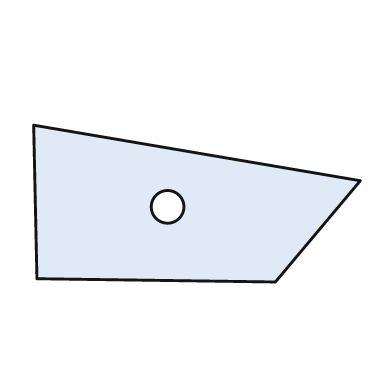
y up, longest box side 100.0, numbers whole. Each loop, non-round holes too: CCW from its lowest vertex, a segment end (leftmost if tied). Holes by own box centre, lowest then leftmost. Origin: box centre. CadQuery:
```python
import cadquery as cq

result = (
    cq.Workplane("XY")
    .moveTo(24.0, -24.0)
    .lineTo(50.0, 7.0)
    .lineTo(-50.0, 24.0)
    .lineTo(-49.0, -23.0)
    .close()
    .moveTo(-9.0, -1.0)
    .circle(5.0)
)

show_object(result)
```